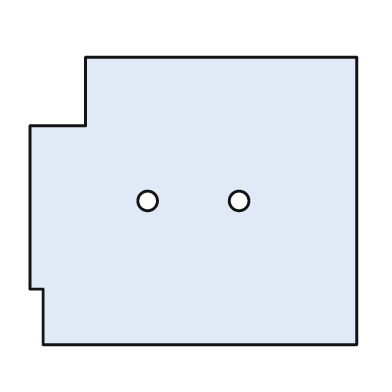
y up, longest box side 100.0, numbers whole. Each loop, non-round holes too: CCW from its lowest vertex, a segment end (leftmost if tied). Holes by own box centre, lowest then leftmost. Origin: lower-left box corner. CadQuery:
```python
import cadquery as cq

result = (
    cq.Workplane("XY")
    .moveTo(4.0, 0.0)
    .lineTo(100.0, 0.0)
    .lineTo(100.0, 88.0)
    .lineTo(17.0, 88.0)
    .lineTo(17.0, 67.0)
    .lineTo(0.0, 67.0)
    .lineTo(0.0, 17.0)
    .lineTo(4.0, 17.0)
    .close()
    .moveTo(36.0, 44.0)
    .circle(3.0)
    .moveTo(64.0, 44.0)
    .circle(3.0)
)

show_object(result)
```